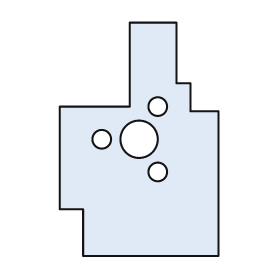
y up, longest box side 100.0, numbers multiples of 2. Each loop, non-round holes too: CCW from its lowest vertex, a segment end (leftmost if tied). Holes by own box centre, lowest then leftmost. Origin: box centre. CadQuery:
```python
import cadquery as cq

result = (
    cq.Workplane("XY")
    .moveTo(-24.0, -50.0)
    .lineTo(34.0, -50.0)
    .lineTo(34.0, 12.0)
    .lineTo(22.0, 12.0)
    .lineTo(22.0, 24.0)
    .lineTo(16.0, 24.0)
    .lineTo(16.0, 50.0)
    .lineTo(-4.0, 50.0)
    .lineTo(-4.0, 14.0)
    .lineTo(-34.0, 14.0)
    .lineTo(-34.0, -30.0)
    .lineTo(-24.0, -30.0)
    .close()
    .moveTo(8.0, -14.0)
    .circle(4.0)
    .moveTo(-16.0, 0.0)
    .circle(4.0)
    .moveTo(0.0, 0.0)
    .circle(8.0)
    .moveTo(8.0, 14.0)
    .circle(4.0)
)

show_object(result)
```